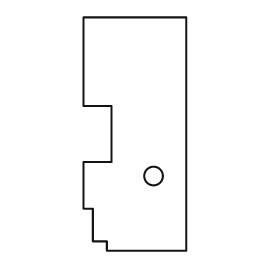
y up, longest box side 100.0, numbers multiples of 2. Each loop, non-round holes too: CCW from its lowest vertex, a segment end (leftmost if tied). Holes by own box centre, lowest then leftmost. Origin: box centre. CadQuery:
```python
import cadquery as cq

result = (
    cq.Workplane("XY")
    .moveTo(-12.0, -50.0)
    .lineTo(22.0, -50.0)
    .lineTo(22.0, 50.0)
    .lineTo(-22.0, 50.0)
    .lineTo(-22.0, 12.0)
    .lineTo(-10.0, 12.0)
    .lineTo(-10.0, -12.0)
    .lineTo(-22.0, -12.0)
    .lineTo(-22.0, -32.0)
    .lineTo(-18.0, -32.0)
    .lineTo(-18.0, -46.0)
    .lineTo(-12.0, -46.0)
    .close()
    .moveTo(8.0, -18.0)
    .circle(4.0)
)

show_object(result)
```